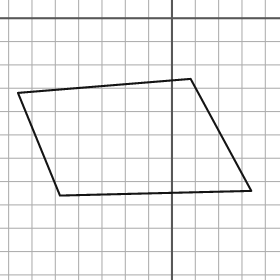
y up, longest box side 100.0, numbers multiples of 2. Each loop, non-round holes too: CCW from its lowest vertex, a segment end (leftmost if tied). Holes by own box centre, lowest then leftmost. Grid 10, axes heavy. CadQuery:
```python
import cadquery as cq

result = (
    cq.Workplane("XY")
    .moveTo(-48.0, -76.0)
    .lineTo(34.0, -74.0)
    .lineTo(8.0, -26.0)
    .lineTo(-66.0, -32.0)
    .close()
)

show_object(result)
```